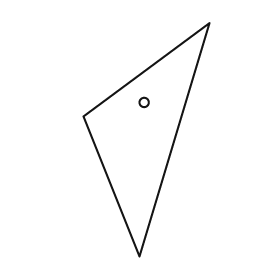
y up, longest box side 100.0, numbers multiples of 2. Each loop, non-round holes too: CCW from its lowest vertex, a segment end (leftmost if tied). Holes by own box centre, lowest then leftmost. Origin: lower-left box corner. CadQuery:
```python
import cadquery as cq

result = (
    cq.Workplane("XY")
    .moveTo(24.0, 0.0)
    .lineTo(54.0, 100.0)
    .lineTo(0.0, 60.0)
    .close()
    .moveTo(26.0, 66.0)
    .circle(2.0)
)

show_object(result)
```